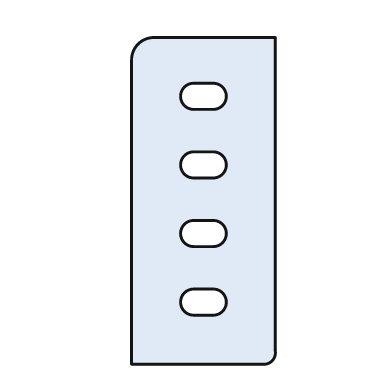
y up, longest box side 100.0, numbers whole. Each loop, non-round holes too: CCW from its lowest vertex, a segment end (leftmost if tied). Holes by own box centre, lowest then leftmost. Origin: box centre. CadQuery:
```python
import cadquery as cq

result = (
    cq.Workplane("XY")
    .moveTo(-22.0, -50.0)
    .lineTo(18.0, -50.0)
    .threePointArc((21.0, -49.0), (22.0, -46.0))
    .lineTo(22.0, 50.0)
    .lineTo(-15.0, 50.0)
    .threePointArc((-20.0, 48.0), (-22.0, 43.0))
    .close()
    .moveTo(-3.0, -35.0)
    .lineTo(3.0, -35.0)
    .threePointArc((7.0, -31.0), (3.0, -27.0))
    .lineTo(-3.0, -27.0)
    .threePointArc((-7.0, -31.0), (-3.0, -35.0))
    .close()
    .moveTo(-3.0, -14.0)
    .lineTo(3.0, -14.0)
    .threePointArc((7.0, -10.0), (3.0, -6.0))
    .lineTo(-3.0, -6.0)
    .threePointArc((-7.0, -10.0), (-3.0, -14.0))
    .close()
    .moveTo(-3.0, 7.0)
    .lineTo(3.0, 7.0)
    .threePointArc((7.0, 11.0), (3.0, 15.0))
    .lineTo(-3.0, 15.0)
    .threePointArc((-7.0, 11.0), (-3.0, 7.0))
    .close()
    .moveTo(-3.0, 28.0)
    .lineTo(3.0, 28.0)
    .threePointArc((7.0, 32.0), (3.0, 36.0))
    .lineTo(-3.0, 36.0)
    .threePointArc((-7.0, 32.0), (-3.0, 28.0))
    .close()
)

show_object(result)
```